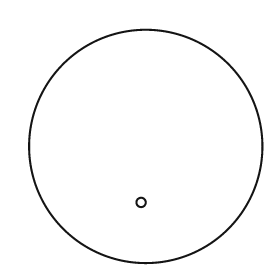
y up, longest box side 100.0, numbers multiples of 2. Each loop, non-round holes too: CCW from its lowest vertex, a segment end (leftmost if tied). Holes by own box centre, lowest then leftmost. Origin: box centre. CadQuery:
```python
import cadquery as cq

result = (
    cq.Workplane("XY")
    .moveTo(0.0, 0.0)
    .circle(50.0)
    .moveTo(-2.0, -24.0)
    .circle(2.0)
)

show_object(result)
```